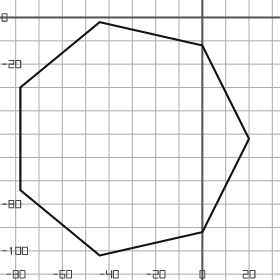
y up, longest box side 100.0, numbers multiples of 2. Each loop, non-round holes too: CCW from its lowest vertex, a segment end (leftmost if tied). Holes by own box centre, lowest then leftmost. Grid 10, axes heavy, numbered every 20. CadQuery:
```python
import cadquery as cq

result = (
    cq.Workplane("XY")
    .moveTo(-44.0, -102.0)
    .lineTo(0.0, -92.0)
    .lineTo(20.0, -52.0)
    .lineTo(0.0, -12.0)
    .lineTo(-44.0, -2.0)
    .lineTo(-78.0, -30.0)
    .lineTo(-78.0, -74.0)
    .close()
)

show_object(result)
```